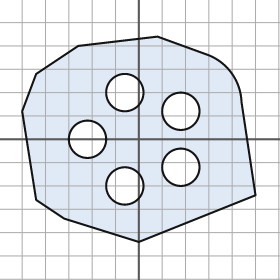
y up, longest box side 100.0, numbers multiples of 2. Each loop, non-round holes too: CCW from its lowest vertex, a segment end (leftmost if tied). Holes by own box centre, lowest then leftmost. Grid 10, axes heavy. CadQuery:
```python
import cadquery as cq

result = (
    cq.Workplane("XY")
    .moveTo(0.0, -44.0)
    .lineTo(50.0, -24.0)
    .lineTo(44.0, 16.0)
    .threePointArc((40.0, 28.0), (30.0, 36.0))
    .lineTo(8.0, 44.0)
    .lineTo(-26.0, 40.0)
    .lineTo(-44.0, 28.0)
    .lineTo(-50.0, 12.0)
    .lineTo(-44.0, -26.0)
    .lineTo(-32.0, -34.0)
    .close()
    .moveTo(-6.0, -20.0)
    .circle(8.0)
    .moveTo(18.0, -12.0)
    .circle(8.0)
    .moveTo(-22.0, 0.0)
    .circle(8.0)
    .moveTo(18.0, 12.0)
    .circle(8.0)
    .moveTo(-6.0, 20.0)
    .circle(8.0)
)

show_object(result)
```